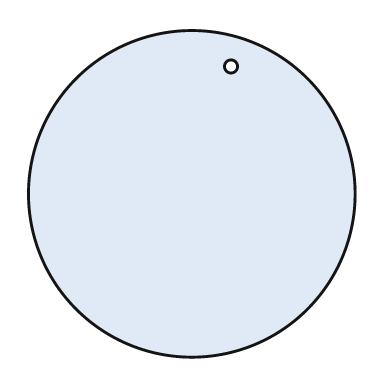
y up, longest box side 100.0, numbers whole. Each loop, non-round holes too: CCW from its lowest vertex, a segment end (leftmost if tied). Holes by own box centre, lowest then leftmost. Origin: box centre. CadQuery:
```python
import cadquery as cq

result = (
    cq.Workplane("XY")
    .moveTo(0.0, 0.0)
    .circle(50.0)
    .moveTo(12.0, 39.0)
    .circle(2.0)
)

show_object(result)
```